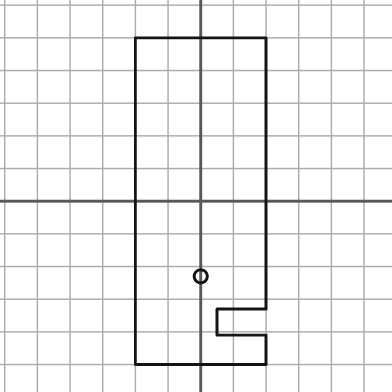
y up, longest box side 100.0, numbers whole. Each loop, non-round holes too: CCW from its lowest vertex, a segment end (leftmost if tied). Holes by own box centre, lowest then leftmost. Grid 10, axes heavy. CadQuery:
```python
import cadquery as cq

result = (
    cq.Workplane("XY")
    .moveTo(-20.0, -50.0)
    .lineTo(20.0, -50.0)
    .lineTo(20.0, -41.0)
    .lineTo(5.0, -41.0)
    .lineTo(5.0, -33.0)
    .lineTo(20.0, -33.0)
    .lineTo(20.0, 50.0)
    .lineTo(-20.0, 50.0)
    .close()
    .moveTo(0.0, -23.0)
    .circle(2.0)
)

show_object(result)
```